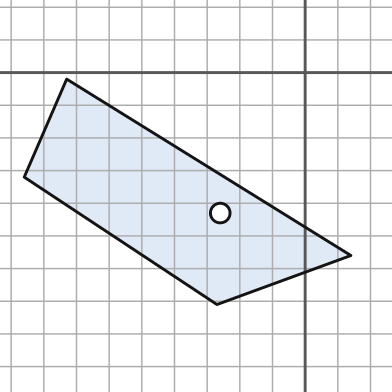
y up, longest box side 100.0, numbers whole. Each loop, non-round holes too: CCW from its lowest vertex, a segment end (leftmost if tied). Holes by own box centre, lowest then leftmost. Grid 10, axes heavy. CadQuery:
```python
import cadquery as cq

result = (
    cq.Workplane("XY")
    .moveTo(-27.0, -71.0)
    .lineTo(14.0, -56.0)
    .lineTo(-73.0, -2.0)
    .lineTo(-86.0, -32.0)
    .close()
    .moveTo(-26.0, -43.0)
    .circle(3.0)
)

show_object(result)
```